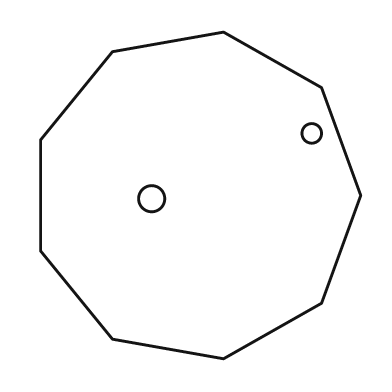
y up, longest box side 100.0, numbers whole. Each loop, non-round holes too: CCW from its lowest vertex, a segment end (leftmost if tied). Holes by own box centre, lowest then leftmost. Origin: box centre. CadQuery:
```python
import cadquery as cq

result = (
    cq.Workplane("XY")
    .moveTo(7.0, -50.0)
    .lineTo(37.0, -33.0)
    .lineTo(49.0, 0.0)
    .lineTo(37.0, 33.0)
    .lineTo(7.0, 50.0)
    .lineTo(-27.0, 44.0)
    .lineTo(-49.0, 17.0)
    .lineTo(-49.0, -17.0)
    .lineTo(-27.0, -44.0)
    .close()
    .moveTo(-15.0, -1.0)
    .circle(4.0)
    .moveTo(34.0, 19.0)
    .circle(3.0)
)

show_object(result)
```